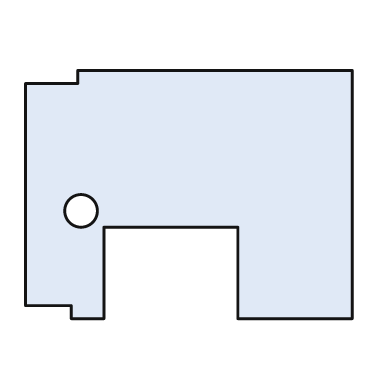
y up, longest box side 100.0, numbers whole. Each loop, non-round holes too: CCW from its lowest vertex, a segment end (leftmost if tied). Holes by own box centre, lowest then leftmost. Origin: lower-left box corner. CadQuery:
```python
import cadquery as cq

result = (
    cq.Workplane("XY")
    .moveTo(14.0, 0.0)
    .lineTo(24.0, 0.0)
    .lineTo(24.0, 28.0)
    .lineTo(65.0, 28.0)
    .lineTo(65.0, 0.0)
    .lineTo(100.0, 0.0)
    .lineTo(100.0, 76.0)
    .lineTo(16.0, 76.0)
    .lineTo(16.0, 72.0)
    .lineTo(0.0, 72.0)
    .lineTo(0.0, 4.0)
    .lineTo(14.0, 4.0)
    .close()
    .moveTo(17.0, 33.0)
    .circle(5.0)
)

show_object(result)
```